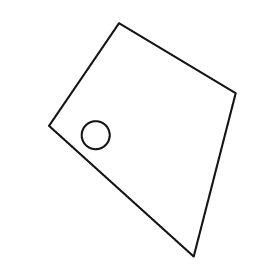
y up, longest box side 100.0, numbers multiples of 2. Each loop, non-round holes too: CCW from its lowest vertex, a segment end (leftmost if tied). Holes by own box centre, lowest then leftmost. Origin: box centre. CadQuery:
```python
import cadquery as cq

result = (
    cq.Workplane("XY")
    .moveTo(22.0, -50.0)
    .lineTo(40.0, 20.0)
    .lineTo(-10.0, 50.0)
    .lineTo(-40.0, 6.0)
    .close()
    .moveTo(-20.0, 2.0)
    .circle(6.0)
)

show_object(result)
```